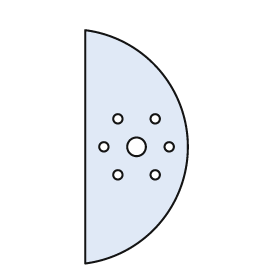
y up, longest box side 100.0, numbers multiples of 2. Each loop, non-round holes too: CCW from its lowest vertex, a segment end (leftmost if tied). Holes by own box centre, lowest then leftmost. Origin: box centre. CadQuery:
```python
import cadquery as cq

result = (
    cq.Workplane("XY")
    .moveTo(-22.0, -50.0)
    .threePointArc((22.0, 0.0), (-22.0, 50.0))
    .close()
    .moveTo(-8.0, -12.0)
    .circle(2.0)
    .moveTo(8.0, -12.0)
    .circle(2.0)
    .moveTo(-14.0, 0.0)
    .circle(2.0)
    .moveTo(0.0, 0.0)
    .circle(4.0)
    .moveTo(14.0, 0.0)
    .circle(2.0)
    .moveTo(-8.0, 12.0)
    .circle(2.0)
    .moveTo(8.0, 12.0)
    .circle(2.0)
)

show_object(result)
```